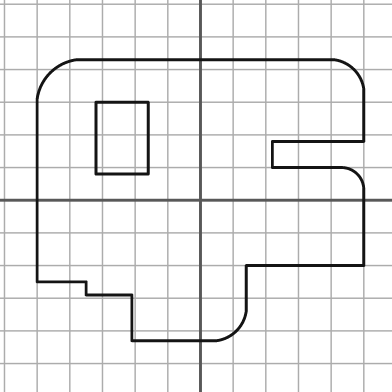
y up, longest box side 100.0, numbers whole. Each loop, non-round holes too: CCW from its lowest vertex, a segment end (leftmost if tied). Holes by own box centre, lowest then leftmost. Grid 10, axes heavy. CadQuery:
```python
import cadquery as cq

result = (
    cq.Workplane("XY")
    .moveTo(-21.0, -43.0)
    .lineTo(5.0, -43.0)
    .threePointArc((11.0, -40.0), (14.0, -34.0))
    .lineTo(14.0, -20.0)
    .lineTo(50.0, -20.0)
    .lineTo(50.0, 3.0)
    .threePointArc((48.0, 8.0), (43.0, 10.0))
    .lineTo(22.0, 10.0)
    .lineTo(22.0, 18.0)
    .lineTo(50.0, 18.0)
    .lineTo(50.0, 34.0)
    .threePointArc((47.0, 40.0), (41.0, 43.0))
    .lineTo(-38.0, 43.0)
    .threePointArc((-46.0, 39.0), (-50.0, 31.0))
    .lineTo(-50.0, -25.0)
    .lineTo(-35.0, -25.0)
    .lineTo(-35.0, -29.0)
    .lineTo(-21.0, -29.0)
    .close()
    .moveTo(-32.0, 8.0)
    .lineTo(-16.0, 8.0)
    .lineTo(-16.0, 30.0)
    .lineTo(-32.0, 30.0)
    .close()
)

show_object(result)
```